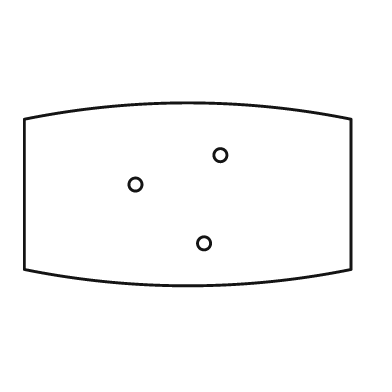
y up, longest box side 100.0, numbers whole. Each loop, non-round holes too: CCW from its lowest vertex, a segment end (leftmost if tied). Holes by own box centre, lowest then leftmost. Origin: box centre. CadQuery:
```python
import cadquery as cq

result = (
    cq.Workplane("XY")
    .moveTo(-50.0, -23.0)
    .threePointArc((0.0, -28.0), (50.0, -23.0))
    .lineTo(50.0, 23.0)
    .threePointArc((0.0, 28.0), (-50.0, 23.0))
    .close()
    .moveTo(5.0, -15.0)
    .circle(2.0)
    .moveTo(-16.0, 3.0)
    .circle(2.0)
    .moveTo(10.0, 12.0)
    .circle(2.0)
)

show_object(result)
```